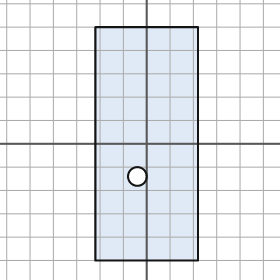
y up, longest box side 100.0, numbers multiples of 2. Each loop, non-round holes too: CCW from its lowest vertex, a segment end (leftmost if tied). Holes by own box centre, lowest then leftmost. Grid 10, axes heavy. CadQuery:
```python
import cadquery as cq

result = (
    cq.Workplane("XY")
    .moveTo(-22.0, -50.0)
    .lineTo(22.0, -50.0)
    .lineTo(22.0, 50.0)
    .lineTo(-22.0, 50.0)
    .close()
    .moveTo(-4.0, -14.0)
    .circle(4.0)
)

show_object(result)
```